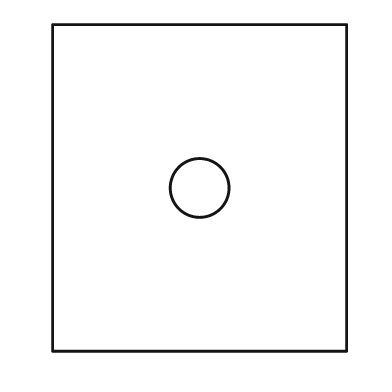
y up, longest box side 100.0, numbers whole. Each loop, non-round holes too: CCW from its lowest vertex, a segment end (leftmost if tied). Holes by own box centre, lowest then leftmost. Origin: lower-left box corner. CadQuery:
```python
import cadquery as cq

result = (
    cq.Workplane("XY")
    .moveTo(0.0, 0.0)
    .lineTo(90.0, 0.0)
    .lineTo(90.0, 100.0)
    .lineTo(0.0, 100.0)
    .close()
    .moveTo(45.0, 50.0)
    .circle(9.0)
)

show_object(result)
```